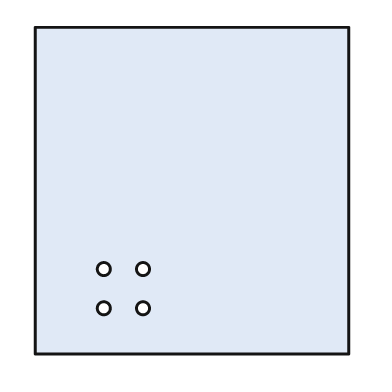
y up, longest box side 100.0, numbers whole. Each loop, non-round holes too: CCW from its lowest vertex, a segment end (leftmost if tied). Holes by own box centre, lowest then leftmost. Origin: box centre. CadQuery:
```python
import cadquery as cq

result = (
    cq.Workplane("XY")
    .moveTo(-48.0, -50.0)
    .lineTo(48.0, -50.0)
    .lineTo(48.0, 50.0)
    .lineTo(-48.0, 50.0)
    .close()
    .moveTo(-27.0, -36.0)
    .circle(2.0)
    .moveTo(-15.0, -36.0)
    .circle(2.0)
    .moveTo(-27.0, -24.0)
    .circle(2.0)
    .moveTo(-15.0, -24.0)
    .circle(2.0)
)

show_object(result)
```